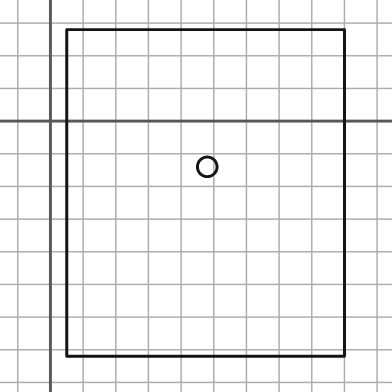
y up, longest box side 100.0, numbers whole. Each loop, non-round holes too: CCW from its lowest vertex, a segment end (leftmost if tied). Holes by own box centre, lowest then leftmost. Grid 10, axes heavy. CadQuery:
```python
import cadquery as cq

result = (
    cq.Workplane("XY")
    .moveTo(5.0, -72.0)
    .lineTo(90.0, -72.0)
    .lineTo(90.0, 28.0)
    .lineTo(5.0, 28.0)
    .close()
    .moveTo(48.0, -14.0)
    .circle(3.0)
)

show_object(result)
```